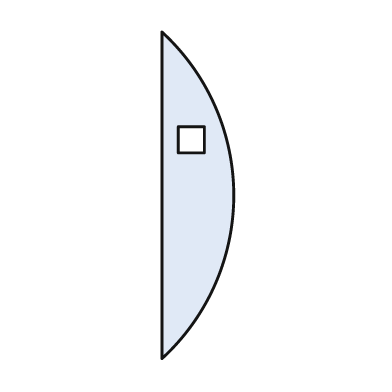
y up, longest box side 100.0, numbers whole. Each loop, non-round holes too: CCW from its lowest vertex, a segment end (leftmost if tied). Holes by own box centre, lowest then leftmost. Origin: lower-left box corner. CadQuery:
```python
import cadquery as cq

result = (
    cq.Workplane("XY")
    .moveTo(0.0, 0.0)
    .threePointArc((22.0, 50.0), (0.0, 100.0))
    .close()
    .moveTo(5.0, 63.0)
    .lineTo(13.0, 63.0)
    .lineTo(13.0, 71.0)
    .lineTo(5.0, 71.0)
    .close()
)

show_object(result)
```